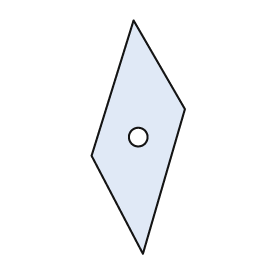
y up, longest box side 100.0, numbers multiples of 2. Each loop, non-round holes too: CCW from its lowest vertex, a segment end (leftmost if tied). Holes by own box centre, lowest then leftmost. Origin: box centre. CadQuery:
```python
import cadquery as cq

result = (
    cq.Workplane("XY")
    .moveTo(2.0, -50.0)
    .lineTo(20.0, 12.0)
    .lineTo(-2.0, 50.0)
    .lineTo(-20.0, -8.0)
    .close()
    .moveTo(0.0, 0.0)
    .circle(4.0)
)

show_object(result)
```